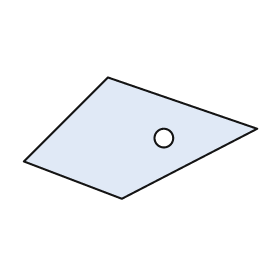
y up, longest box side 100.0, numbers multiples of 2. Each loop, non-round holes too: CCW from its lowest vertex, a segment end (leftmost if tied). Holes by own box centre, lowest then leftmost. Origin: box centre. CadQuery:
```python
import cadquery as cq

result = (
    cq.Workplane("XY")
    .moveTo(-8.0, -26.0)
    .lineTo(50.0, 4.0)
    .lineTo(-14.0, 26.0)
    .lineTo(-50.0, -10.0)
    .close()
    .moveTo(10.0, 0.0)
    .circle(4.0)
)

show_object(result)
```